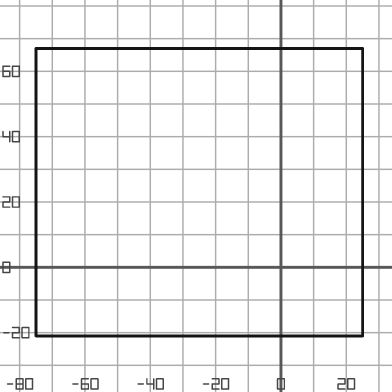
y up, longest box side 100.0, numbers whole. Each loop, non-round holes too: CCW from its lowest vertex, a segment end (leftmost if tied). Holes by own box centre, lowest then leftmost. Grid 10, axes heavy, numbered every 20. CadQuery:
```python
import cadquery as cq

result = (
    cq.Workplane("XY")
    .moveTo(-75.0, -21.0)
    .lineTo(25.0, -21.0)
    .lineTo(25.0, 67.0)
    .lineTo(-75.0, 67.0)
    .close()
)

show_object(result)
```